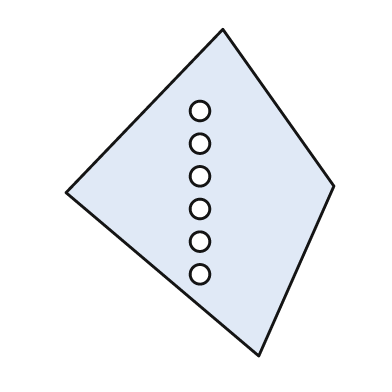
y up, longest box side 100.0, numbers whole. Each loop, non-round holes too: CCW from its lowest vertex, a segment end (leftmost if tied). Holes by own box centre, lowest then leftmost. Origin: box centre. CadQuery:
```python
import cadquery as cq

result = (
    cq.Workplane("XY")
    .moveTo(18.0, -50.0)
    .lineTo(41.0, 2.0)
    .lineTo(7.0, 50.0)
    .lineTo(-41.0, 0.0)
    .close()
    .moveTo(0.0, -25.0)
    .circle(3.0)
    .moveTo(0.0, -15.0)
    .circle(3.0)
    .moveTo(0.0, -5.0)
    .circle(3.0)
    .moveTo(0.0, 5.0)
    .circle(3.0)
    .moveTo(0.0, 15.0)
    .circle(3.0)
    .moveTo(0.0, 25.0)
    .circle(3.0)
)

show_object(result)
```